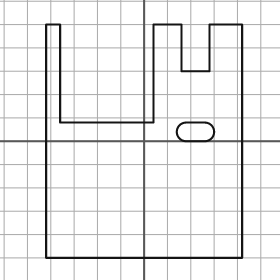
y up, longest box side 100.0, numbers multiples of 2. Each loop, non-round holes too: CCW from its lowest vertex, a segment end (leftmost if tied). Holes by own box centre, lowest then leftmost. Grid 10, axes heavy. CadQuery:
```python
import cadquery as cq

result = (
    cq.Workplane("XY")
    .moveTo(-42.0, -50.0)
    .lineTo(42.0, -50.0)
    .lineTo(42.0, 50.0)
    .lineTo(28.0, 50.0)
    .lineTo(28.0, 30.0)
    .lineTo(16.0, 30.0)
    .lineTo(16.0, 50.0)
    .lineTo(4.0, 50.0)
    .lineTo(4.0, 8.0)
    .lineTo(-36.0, 8.0)
    .lineTo(-36.0, 50.0)
    .lineTo(-42.0, 50.0)
    .close()
    .moveTo(18.0, 0.0)
    .lineTo(26.0, 0.0)
    .threePointArc((30.0, 4.0), (26.0, 8.0))
    .lineTo(18.0, 8.0)
    .threePointArc((14.0, 4.0), (18.0, 0.0))
    .close()
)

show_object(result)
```